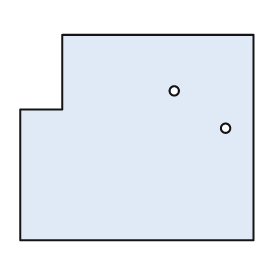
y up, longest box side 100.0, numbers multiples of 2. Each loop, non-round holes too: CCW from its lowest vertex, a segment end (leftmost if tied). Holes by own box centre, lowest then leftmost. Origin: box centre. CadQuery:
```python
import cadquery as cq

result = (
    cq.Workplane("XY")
    .moveTo(-50.0, -44.0)
    .lineTo(50.0, -44.0)
    .lineTo(50.0, 44.0)
    .lineTo(-32.0, 44.0)
    .lineTo(-32.0, 12.0)
    .lineTo(-50.0, 12.0)
    .close()
    .moveTo(38.0, 4.0)
    .circle(2.0)
    .moveTo(16.0, 20.0)
    .circle(2.0)
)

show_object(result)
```